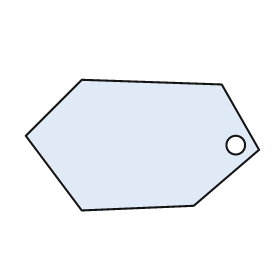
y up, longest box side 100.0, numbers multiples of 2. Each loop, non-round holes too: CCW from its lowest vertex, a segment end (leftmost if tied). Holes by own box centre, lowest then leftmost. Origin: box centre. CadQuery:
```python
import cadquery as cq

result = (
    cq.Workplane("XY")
    .moveTo(-26.0, -28.0)
    .lineTo(22.0, -26.0)
    .lineTo(50.0, -2.0)
    .lineTo(34.0, 26.0)
    .lineTo(-26.0, 28.0)
    .lineTo(-50.0, 4.0)
    .close()
    .moveTo(40.0, 0.0)
    .circle(4.0)
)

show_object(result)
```